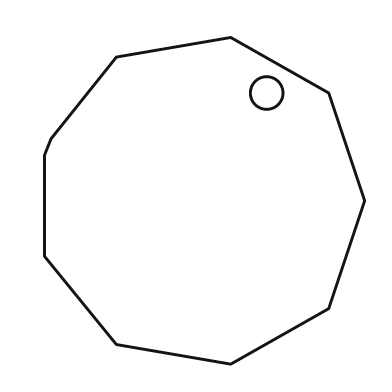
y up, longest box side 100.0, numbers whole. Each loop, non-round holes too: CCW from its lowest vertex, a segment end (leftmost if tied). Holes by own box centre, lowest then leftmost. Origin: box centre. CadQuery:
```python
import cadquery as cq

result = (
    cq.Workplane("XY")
    .moveTo(8.0, -50.0)
    .lineTo(38.0, -33.0)
    .lineTo(49.0, 0.0)
    .lineTo(38.0, 33.0)
    .lineTo(8.0, 50.0)
    .lineTo(-27.0, 44.0)
    .lineTo(-47.0, 19.0)
    .lineTo(-49.0, 14.0)
    .lineTo(-49.0, -17.0)
    .lineTo(-27.0, -44.0)
    .close()
    .moveTo(19.0, 33.0)
    .circle(5.0)
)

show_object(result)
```